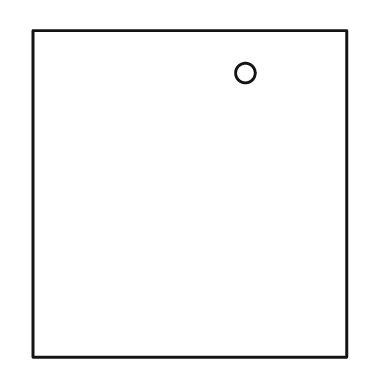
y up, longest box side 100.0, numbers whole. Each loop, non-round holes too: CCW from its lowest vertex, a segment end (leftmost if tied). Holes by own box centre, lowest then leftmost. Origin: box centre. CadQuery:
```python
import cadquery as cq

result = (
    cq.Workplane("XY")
    .moveTo(-48.0, -50.0)
    .lineTo(48.0, -50.0)
    .lineTo(48.0, 50.0)
    .lineTo(-48.0, 50.0)
    .close()
    .moveTo(17.0, 37.0)
    .circle(3.0)
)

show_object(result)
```